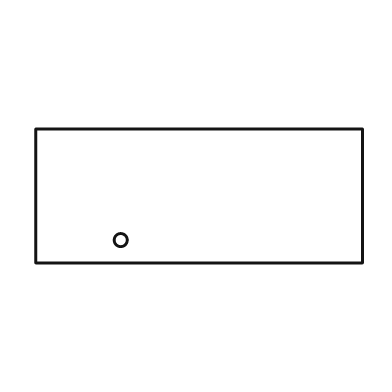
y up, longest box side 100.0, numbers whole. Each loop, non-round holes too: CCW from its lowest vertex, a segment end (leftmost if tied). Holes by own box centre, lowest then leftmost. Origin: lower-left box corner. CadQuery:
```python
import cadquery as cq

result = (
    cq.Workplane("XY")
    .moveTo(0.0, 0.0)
    .lineTo(100.0, 0.0)
    .lineTo(100.0, 41.0)
    .lineTo(0.0, 41.0)
    .close()
    .moveTo(26.0, 7.0)
    .circle(2.0)
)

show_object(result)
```